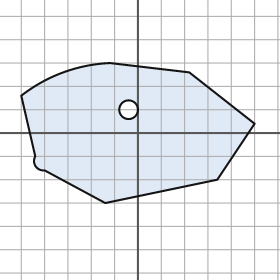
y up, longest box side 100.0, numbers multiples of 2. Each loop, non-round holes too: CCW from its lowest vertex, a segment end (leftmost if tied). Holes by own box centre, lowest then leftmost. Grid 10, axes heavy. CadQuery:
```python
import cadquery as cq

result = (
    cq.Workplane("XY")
    .moveTo(-14.0, -30.0)
    .lineTo(34.0, -20.0)
    .lineTo(50.0, 4.0)
    .lineTo(22.0, 26.0)
    .lineTo(-12.0, 30.0)
    .threePointArc((-32.0, 26.0), (-50.0, 16.0))
    .lineTo(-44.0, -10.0)
    .threePointArc((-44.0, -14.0), (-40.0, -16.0))
    .close()
    .moveTo(-4.0, 10.0)
    .circle(4.0)
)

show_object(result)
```